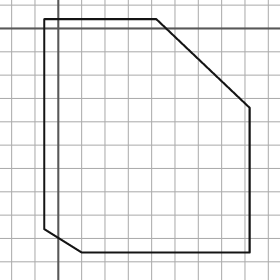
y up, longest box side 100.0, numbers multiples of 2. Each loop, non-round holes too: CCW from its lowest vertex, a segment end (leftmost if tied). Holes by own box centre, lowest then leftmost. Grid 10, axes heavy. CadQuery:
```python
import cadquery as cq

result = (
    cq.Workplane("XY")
    .moveTo(10.0, -96.0)
    .lineTo(82.0, -96.0)
    .lineTo(82.0, -34.0)
    .lineTo(42.0, 4.0)
    .lineTo(-6.0, 4.0)
    .lineTo(-6.0, -86.0)
    .close()
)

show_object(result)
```